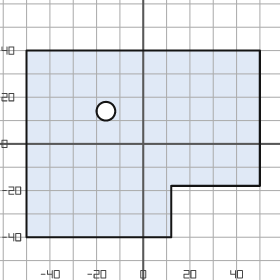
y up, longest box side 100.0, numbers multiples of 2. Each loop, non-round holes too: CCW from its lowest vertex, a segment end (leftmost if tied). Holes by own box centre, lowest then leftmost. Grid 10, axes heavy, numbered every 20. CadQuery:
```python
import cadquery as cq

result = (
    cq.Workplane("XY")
    .moveTo(-50.0, -40.0)
    .lineTo(12.0, -40.0)
    .lineTo(12.0, -18.0)
    .lineTo(50.0, -18.0)
    .lineTo(50.0, 40.0)
    .lineTo(-50.0, 40.0)
    .close()
    .moveTo(-16.0, 14.0)
    .circle(4.0)
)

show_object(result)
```